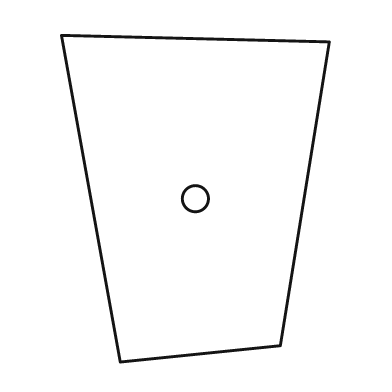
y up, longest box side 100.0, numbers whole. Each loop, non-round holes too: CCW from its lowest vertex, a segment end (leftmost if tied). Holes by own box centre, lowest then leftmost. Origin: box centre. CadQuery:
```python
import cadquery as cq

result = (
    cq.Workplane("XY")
    .moveTo(-23.0, -50.0)
    .lineTo(26.0, -45.0)
    .lineTo(41.0, 48.0)
    .lineTo(-41.0, 50.0)
    .close()
    .moveTo(0.0, 0.0)
    .circle(4.0)
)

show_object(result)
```